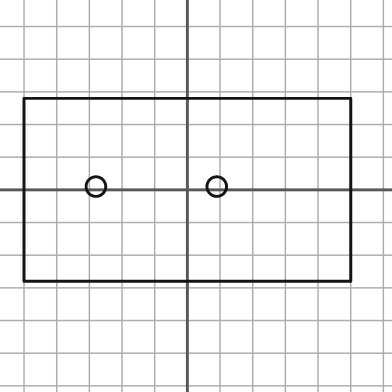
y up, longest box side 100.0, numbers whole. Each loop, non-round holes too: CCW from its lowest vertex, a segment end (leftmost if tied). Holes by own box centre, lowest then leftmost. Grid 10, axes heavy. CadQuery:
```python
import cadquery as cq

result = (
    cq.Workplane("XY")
    .moveTo(-50.0, -28.0)
    .lineTo(50.0, -28.0)
    .lineTo(50.0, 28.0)
    .lineTo(-50.0, 28.0)
    .close()
    .moveTo(-28.0, 1.0)
    .circle(3.0)
    .moveTo(9.0, 1.0)
    .circle(3.0)
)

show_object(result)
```